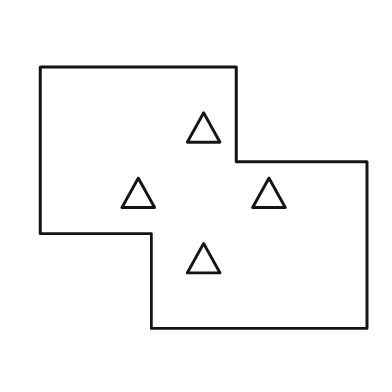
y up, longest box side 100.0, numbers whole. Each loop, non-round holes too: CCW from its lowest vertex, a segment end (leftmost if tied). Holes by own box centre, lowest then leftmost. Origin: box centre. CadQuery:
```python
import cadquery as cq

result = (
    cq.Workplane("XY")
    .moveTo(-16.0, -40.0)
    .lineTo(50.0, -40.0)
    .lineTo(50.0, 11.0)
    .lineTo(10.0, 11.0)
    .lineTo(10.0, 40.0)
    .lineTo(-50.0, 40.0)
    .lineTo(-50.0, -11.0)
    .lineTo(-16.0, -11.0)
    .close()
    .moveTo(-5.0, -23.0)
    .lineTo(5.0, -23.0)
    .lineTo(0.0, -14.0)
    .close()
    .moveTo(-25.0, -3.0)
    .lineTo(-15.0, -3.0)
    .lineTo(-20.0, 6.0)
    .close()
    .moveTo(15.0, -3.0)
    .lineTo(25.0, -3.0)
    .lineTo(20.0, 6.0)
    .close()
    .moveTo(-5.0, 17.0)
    .lineTo(5.0, 17.0)
    .lineTo(0.0, 26.0)
    .close()
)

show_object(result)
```